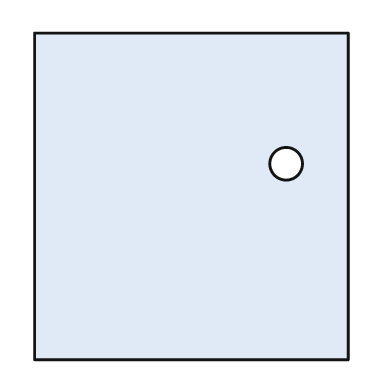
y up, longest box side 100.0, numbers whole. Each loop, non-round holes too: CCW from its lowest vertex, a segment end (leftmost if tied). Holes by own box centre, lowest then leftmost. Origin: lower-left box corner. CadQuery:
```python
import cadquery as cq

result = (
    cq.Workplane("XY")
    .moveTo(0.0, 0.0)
    .lineTo(96.0, 0.0)
    .lineTo(96.0, 100.0)
    .lineTo(0.0, 100.0)
    .close()
    .moveTo(77.0, 60.0)
    .circle(5.0)
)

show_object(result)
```